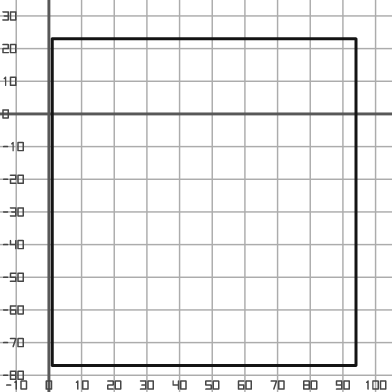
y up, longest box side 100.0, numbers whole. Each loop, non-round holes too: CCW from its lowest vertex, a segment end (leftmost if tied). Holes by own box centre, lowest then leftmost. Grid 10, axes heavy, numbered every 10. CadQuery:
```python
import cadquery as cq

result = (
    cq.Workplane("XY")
    .moveTo(1.0, -77.0)
    .lineTo(94.0, -77.0)
    .lineTo(94.0, 23.0)
    .lineTo(1.0, 23.0)
    .close()
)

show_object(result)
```